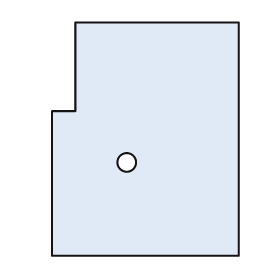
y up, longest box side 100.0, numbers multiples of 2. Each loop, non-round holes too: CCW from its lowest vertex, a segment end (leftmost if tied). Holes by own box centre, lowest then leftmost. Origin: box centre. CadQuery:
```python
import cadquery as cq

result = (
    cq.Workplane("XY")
    .moveTo(-40.0, -50.0)
    .lineTo(40.0, -50.0)
    .lineTo(40.0, 50.0)
    .lineTo(-30.0, 50.0)
    .lineTo(-30.0, 12.0)
    .lineTo(-40.0, 12.0)
    .close()
    .moveTo(-8.0, -10.0)
    .circle(4.0)
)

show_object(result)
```